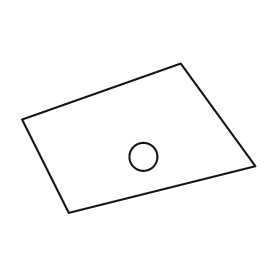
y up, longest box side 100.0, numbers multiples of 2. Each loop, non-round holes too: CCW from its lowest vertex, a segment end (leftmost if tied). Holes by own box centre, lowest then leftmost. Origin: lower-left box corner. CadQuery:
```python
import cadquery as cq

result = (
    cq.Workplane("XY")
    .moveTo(20.0, 0.0)
    .lineTo(100.0, 20.0)
    .lineTo(68.0, 64.0)
    .lineTo(0.0, 40.0)
    .close()
    .moveTo(52.0, 24.0)
    .circle(6.0)
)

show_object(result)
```